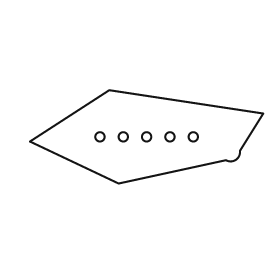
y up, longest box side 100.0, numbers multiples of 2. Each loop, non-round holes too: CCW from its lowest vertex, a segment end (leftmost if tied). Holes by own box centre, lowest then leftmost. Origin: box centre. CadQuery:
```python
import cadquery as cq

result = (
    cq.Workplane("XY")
    .moveTo(-12.0, -20.0)
    .lineTo(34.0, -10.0)
    .threePointArc((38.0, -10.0), (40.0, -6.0))
    .lineTo(50.0, 10.0)
    .lineTo(-16.0, 20.0)
    .lineTo(-50.0, -2.0)
    .close()
    .moveTo(-20.0, 0.0)
    .circle(2.0)
    .moveTo(-10.0, 0.0)
    .circle(2.0)
    .moveTo(0.0, 0.0)
    .circle(2.0)
    .moveTo(10.0, 0.0)
    .circle(2.0)
    .moveTo(20.0, 0.0)
    .circle(2.0)
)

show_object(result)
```